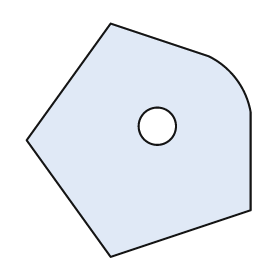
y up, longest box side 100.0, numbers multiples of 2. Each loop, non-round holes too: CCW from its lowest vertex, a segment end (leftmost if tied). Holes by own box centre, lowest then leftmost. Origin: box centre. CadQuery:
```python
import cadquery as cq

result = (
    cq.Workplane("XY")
    .moveTo(-12.0, -50.0)
    .lineTo(48.0, -30.0)
    .lineTo(48.0, 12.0)
    .threePointArc((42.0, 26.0), (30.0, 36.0))
    .lineTo(-12.0, 50.0)
    .lineTo(-48.0, 0.0)
    .close()
    .moveTo(8.0, 6.0)
    .circle(8.0)
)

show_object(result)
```